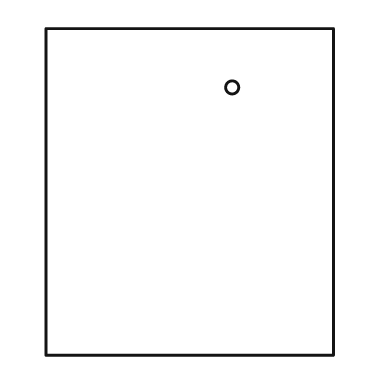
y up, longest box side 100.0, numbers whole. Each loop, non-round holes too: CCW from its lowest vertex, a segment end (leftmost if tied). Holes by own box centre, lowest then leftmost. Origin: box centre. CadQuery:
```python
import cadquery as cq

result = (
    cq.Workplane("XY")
    .moveTo(-44.0, -50.0)
    .lineTo(44.0, -50.0)
    .lineTo(44.0, 50.0)
    .lineTo(-44.0, 50.0)
    .close()
    .moveTo(13.0, 32.0)
    .circle(2.0)
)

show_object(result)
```